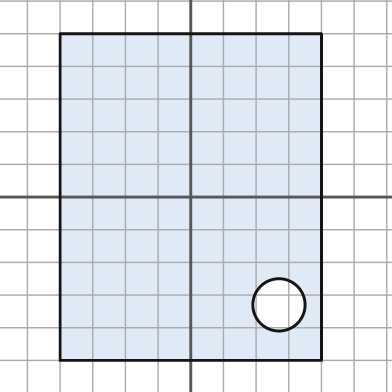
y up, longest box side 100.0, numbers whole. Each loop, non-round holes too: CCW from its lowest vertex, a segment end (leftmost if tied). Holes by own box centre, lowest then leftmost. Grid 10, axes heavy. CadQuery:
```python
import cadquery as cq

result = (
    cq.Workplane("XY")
    .moveTo(-40.0, -50.0)
    .lineTo(40.0, -50.0)
    .lineTo(40.0, 50.0)
    .lineTo(-40.0, 50.0)
    .close()
    .moveTo(27.0, -33.0)
    .circle(8.0)
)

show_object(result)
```